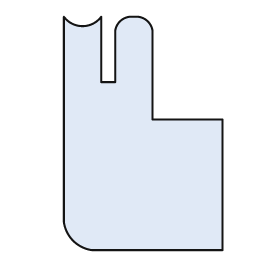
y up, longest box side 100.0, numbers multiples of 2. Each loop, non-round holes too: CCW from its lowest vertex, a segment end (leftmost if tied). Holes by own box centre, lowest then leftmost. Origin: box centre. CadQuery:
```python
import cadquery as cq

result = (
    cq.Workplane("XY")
    .moveTo(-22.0, -50.0)
    .lineTo(34.0, -50.0)
    .lineTo(34.0, 6.0)
    .lineTo(4.0, 6.0)
    .lineTo(4.0, 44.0)
    .threePointArc((2.0, 48.0), (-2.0, 50.0))
    .lineTo(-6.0, 50.0)
    .threePointArc((-10.0, 48.0), (-12.0, 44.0))
    .lineTo(-12.0, 22.0)
    .lineTo(-18.0, 22.0)
    .lineTo(-18.0, 50.0)
    .threePointArc((-26.0, 46.0), (-34.0, 50.0))
    .lineTo(-34.0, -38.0)
    .threePointArc((-30.0, -46.0), (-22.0, -50.0))
    .close()
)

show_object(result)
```